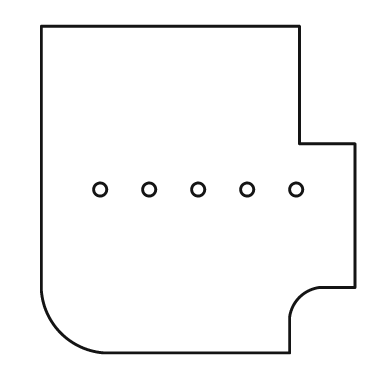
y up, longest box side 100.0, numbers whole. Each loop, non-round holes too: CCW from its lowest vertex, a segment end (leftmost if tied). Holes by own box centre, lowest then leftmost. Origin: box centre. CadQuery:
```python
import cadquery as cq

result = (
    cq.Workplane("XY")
    .moveTo(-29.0, -50.0)
    .lineTo(28.0, -50.0)
    .lineTo(28.0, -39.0)
    .threePointArc((31.0, -33.0), (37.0, -30.0))
    .lineTo(48.0, -30.0)
    .lineTo(48.0, 14.0)
    .lineTo(31.0, 14.0)
    .lineTo(31.0, 50.0)
    .lineTo(-48.0, 50.0)
    .lineTo(-48.0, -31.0)
    .threePointArc((-42.0, -44.0), (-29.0, -50.0))
    .close()
    .moveTo(-30.0, 0.0)
    .circle(2.0)
    .moveTo(-15.0, 0.0)
    .circle(2.0)
    .moveTo(0.0, 0.0)
    .circle(2.0)
    .moveTo(15.0, 0.0)
    .circle(2.0)
    .moveTo(30.0, 0.0)
    .circle(2.0)
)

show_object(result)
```